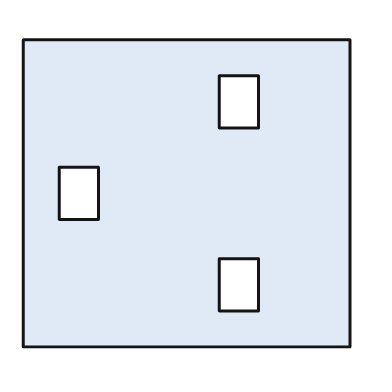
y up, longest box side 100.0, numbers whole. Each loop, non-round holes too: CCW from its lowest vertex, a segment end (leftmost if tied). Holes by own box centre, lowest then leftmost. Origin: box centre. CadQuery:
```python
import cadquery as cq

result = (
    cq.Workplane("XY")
    .moveTo(-50.0, -47.0)
    .lineTo(50.0, -47.0)
    .lineTo(50.0, 47.0)
    .lineTo(-50.0, 47.0)
    .close()
    .moveTo(10.0, -36.0)
    .lineTo(22.0, -36.0)
    .lineTo(22.0, -20.0)
    .lineTo(10.0, -20.0)
    .close()
    .moveTo(-39.0, -8.0)
    .lineTo(-27.0, -8.0)
    .lineTo(-27.0, 8.0)
    .lineTo(-39.0, 8.0)
    .close()
    .moveTo(10.0, 20.0)
    .lineTo(22.0, 20.0)
    .lineTo(22.0, 36.0)
    .lineTo(10.0, 36.0)
    .close()
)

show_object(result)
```